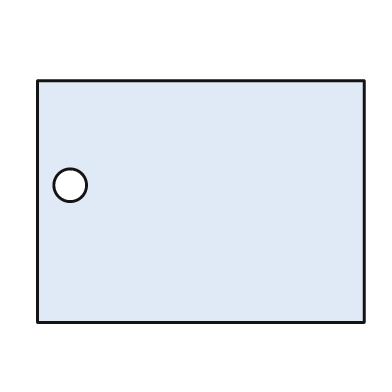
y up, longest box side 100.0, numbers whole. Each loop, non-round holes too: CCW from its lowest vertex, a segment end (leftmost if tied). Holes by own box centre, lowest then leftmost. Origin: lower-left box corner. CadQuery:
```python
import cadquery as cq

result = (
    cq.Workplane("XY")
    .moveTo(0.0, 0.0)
    .lineTo(100.0, 0.0)
    .lineTo(100.0, 74.0)
    .lineTo(0.0, 74.0)
    .close()
    .moveTo(10.0, 42.0)
    .circle(5.0)
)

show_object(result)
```